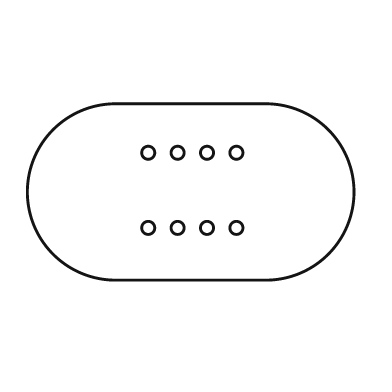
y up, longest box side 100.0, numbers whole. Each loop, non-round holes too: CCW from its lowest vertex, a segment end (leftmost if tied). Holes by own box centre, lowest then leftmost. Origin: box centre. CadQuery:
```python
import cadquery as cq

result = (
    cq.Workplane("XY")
    .moveTo(-23.0, -27.0)
    .lineTo(23.0, -27.0)
    .threePointArc((50.0, 0.0), (23.0, 27.0))
    .lineTo(-23.0, 27.0)
    .threePointArc((-50.0, 0.0), (-23.0, -27.0))
    .close()
    .moveTo(-13.0, -11.0)
    .circle(2.0)
    .moveTo(-4.0, -11.0)
    .circle(2.0)
    .moveTo(5.0, -11.0)
    .circle(2.0)
    .moveTo(14.0, -11.0)
    .circle(2.0)
    .moveTo(-13.0, 12.0)
    .circle(2.0)
    .moveTo(-4.0, 12.0)
    .circle(2.0)
    .moveTo(5.0, 12.0)
    .circle(2.0)
    .moveTo(14.0, 12.0)
    .circle(2.0)
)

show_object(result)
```